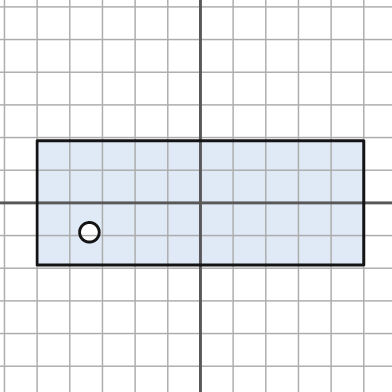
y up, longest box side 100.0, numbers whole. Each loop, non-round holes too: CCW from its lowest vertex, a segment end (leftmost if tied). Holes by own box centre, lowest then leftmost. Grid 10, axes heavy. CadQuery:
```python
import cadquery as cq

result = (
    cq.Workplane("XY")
    .moveTo(-50.0, -19.0)
    .lineTo(50.0, -19.0)
    .lineTo(50.0, 19.0)
    .lineTo(-50.0, 19.0)
    .close()
    .moveTo(-34.0, -9.0)
    .circle(3.0)
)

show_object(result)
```